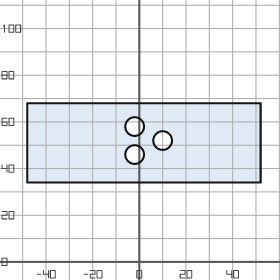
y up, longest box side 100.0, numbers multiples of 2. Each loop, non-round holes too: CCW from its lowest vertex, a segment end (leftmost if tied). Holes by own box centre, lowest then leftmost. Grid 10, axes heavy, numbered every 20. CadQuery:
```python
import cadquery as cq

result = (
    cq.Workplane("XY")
    .moveTo(-48.0, 34.0)
    .lineTo(52.0, 34.0)
    .lineTo(52.0, 68.0)
    .lineTo(-48.0, 68.0)
    .close()
    .moveTo(-2.0, 46.0)
    .circle(4.0)
    .moveTo(10.0, 52.0)
    .circle(4.0)
    .moveTo(-2.0, 58.0)
    .circle(4.0)
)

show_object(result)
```